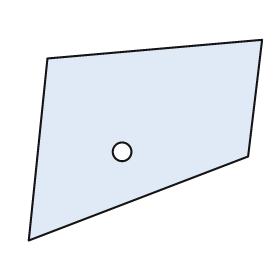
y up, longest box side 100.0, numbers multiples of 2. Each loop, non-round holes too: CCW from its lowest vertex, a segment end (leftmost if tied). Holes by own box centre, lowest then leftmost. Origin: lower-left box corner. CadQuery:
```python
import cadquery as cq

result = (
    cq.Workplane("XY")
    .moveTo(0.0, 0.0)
    .lineTo(94.0, 36.0)
    .lineTo(100.0, 86.0)
    .lineTo(8.0, 78.0)
    .close()
    .moveTo(40.0, 38.0)
    .circle(4.0)
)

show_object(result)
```